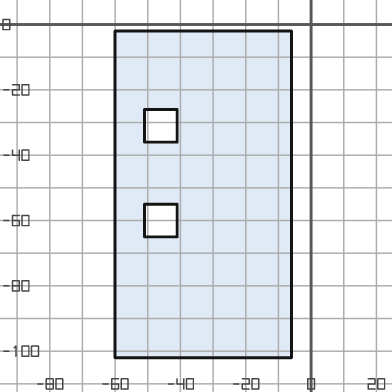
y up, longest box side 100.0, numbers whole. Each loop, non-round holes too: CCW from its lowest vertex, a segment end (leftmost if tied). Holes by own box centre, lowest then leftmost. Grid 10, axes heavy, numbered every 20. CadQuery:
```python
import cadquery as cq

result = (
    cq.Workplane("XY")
    .moveTo(-60.0, -102.0)
    .lineTo(-6.0, -102.0)
    .lineTo(-6.0, -2.0)
    .lineTo(-60.0, -2.0)
    .close()
    .moveTo(-51.0, -65.0)
    .lineTo(-41.0, -65.0)
    .lineTo(-41.0, -55.0)
    .lineTo(-51.0, -55.0)
    .close()
    .moveTo(-51.0, -36.0)
    .lineTo(-41.0, -36.0)
    .lineTo(-41.0, -26.0)
    .lineTo(-51.0, -26.0)
    .close()
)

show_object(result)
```